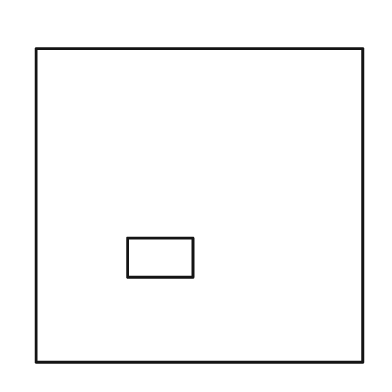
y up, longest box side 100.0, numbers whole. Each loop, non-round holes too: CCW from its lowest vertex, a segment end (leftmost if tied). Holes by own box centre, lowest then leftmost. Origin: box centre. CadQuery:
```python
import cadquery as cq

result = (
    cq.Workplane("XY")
    .moveTo(-50.0, -48.0)
    .lineTo(50.0, -48.0)
    .lineTo(50.0, 48.0)
    .lineTo(-50.0, 48.0)
    .close()
    .moveTo(-22.0, -22.0)
    .lineTo(-2.0, -22.0)
    .lineTo(-2.0, -10.0)
    .lineTo(-22.0, -10.0)
    .close()
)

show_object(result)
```